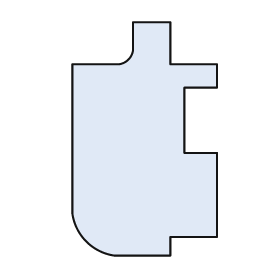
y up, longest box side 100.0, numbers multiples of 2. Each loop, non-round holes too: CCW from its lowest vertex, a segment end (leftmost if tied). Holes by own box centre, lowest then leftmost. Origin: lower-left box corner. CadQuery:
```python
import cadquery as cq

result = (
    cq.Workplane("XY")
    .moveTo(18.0, 0.0)
    .lineTo(42.0, 0.0)
    .lineTo(42.0, 8.0)
    .lineTo(62.0, 8.0)
    .lineTo(62.0, 44.0)
    .lineTo(48.0, 44.0)
    .lineTo(48.0, 72.0)
    .lineTo(62.0, 72.0)
    .lineTo(62.0, 82.0)
    .lineTo(42.0, 82.0)
    .lineTo(42.0, 100.0)
    .lineTo(26.0, 100.0)
    .lineTo(26.0, 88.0)
    .threePointArc((24.0, 84.0), (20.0, 82.0))
    .lineTo(0.0, 82.0)
    .lineTo(0.0, 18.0)
    .threePointArc((6.0, 6.0), (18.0, 0.0))
    .close()
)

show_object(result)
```